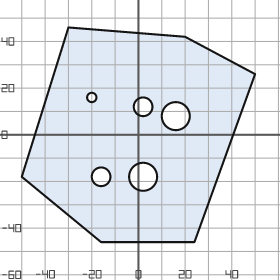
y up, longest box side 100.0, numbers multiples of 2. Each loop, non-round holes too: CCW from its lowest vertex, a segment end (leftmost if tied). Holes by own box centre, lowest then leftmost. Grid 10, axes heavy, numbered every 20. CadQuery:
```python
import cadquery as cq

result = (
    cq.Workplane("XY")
    .moveTo(-16.0, -46.0)
    .lineTo(24.0, -46.0)
    .lineTo(50.0, 26.0)
    .lineTo(20.0, 42.0)
    .lineTo(-30.0, 46.0)
    .lineTo(-50.0, -18.0)
    .close()
    .moveTo(-16.0, -18.0)
    .circle(4.0)
    .moveTo(2.0, -18.0)
    .circle(6.0)
    .moveTo(16.0, 8.0)
    .circle(6.0)
    .moveTo(2.0, 12.0)
    .circle(4.0)
    .moveTo(-20.0, 16.0)
    .circle(2.0)
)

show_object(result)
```